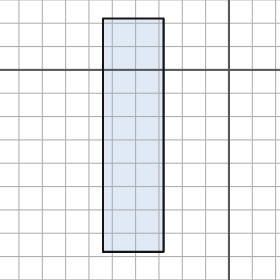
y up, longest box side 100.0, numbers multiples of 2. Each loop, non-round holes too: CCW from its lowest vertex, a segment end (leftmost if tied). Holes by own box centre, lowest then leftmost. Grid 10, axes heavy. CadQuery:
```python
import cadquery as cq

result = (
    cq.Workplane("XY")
    .moveTo(-54.0, -78.0)
    .lineTo(-28.0, -78.0)
    .lineTo(-28.0, 22.0)
    .lineTo(-54.0, 22.0)
    .close()
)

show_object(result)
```